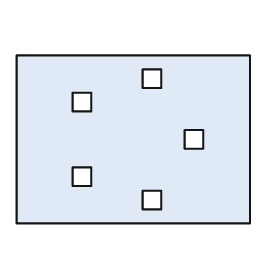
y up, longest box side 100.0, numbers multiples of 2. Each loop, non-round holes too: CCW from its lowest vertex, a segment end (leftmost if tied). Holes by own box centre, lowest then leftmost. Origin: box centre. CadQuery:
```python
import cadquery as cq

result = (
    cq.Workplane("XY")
    .moveTo(-50.0, -36.0)
    .lineTo(50.0, -36.0)
    .lineTo(50.0, 36.0)
    .lineTo(-50.0, 36.0)
    .close()
    .moveTo(4.0, -30.0)
    .lineTo(12.0, -30.0)
    .lineTo(12.0, -22.0)
    .lineTo(4.0, -22.0)
    .close()
    .moveTo(-26.0, -20.0)
    .lineTo(-18.0, -20.0)
    .lineTo(-18.0, -12.0)
    .lineTo(-26.0, -12.0)
    .close()
    .moveTo(22.0, -4.0)
    .lineTo(30.0, -4.0)
    .lineTo(30.0, 4.0)
    .lineTo(22.0, 4.0)
    .close()
    .moveTo(-26.0, 12.0)
    .lineTo(-18.0, 12.0)
    .lineTo(-18.0, 20.0)
    .lineTo(-26.0, 20.0)
    .close()
    .moveTo(4.0, 22.0)
    .lineTo(12.0, 22.0)
    .lineTo(12.0, 30.0)
    .lineTo(4.0, 30.0)
    .close()
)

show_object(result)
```